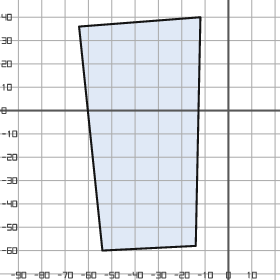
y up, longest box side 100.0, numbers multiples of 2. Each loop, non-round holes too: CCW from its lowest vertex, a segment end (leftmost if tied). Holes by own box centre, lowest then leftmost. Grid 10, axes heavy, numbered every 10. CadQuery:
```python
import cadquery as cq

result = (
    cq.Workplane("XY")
    .moveTo(-54.0, -60.0)
    .lineTo(-14.0, -58.0)
    .lineTo(-12.0, 40.0)
    .lineTo(-64.0, 36.0)
    .close()
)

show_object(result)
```